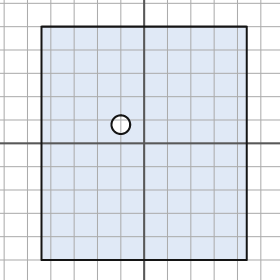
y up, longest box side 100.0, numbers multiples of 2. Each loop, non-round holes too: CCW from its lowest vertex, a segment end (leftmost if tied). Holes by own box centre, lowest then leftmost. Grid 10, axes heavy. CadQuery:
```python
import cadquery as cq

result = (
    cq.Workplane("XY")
    .moveTo(-44.0, -50.0)
    .lineTo(44.0, -50.0)
    .lineTo(44.0, 50.0)
    .lineTo(-44.0, 50.0)
    .close()
    .moveTo(-10.0, 8.0)
    .circle(4.0)
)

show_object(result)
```